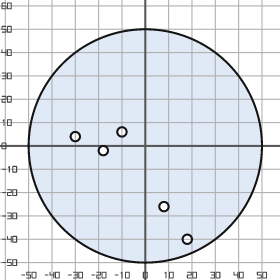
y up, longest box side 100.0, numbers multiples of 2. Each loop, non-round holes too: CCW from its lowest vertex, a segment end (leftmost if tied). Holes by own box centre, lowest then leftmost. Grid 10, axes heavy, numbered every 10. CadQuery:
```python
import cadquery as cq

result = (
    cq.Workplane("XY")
    .moveTo(0.0, 0.0)
    .circle(50.0)
    .moveTo(18.0, -40.0)
    .circle(2.0)
    .moveTo(8.0, -26.0)
    .circle(2.0)
    .moveTo(-18.0, -2.0)
    .circle(2.0)
    .moveTo(-30.0, 4.0)
    .circle(2.0)
    .moveTo(-10.0, 6.0)
    .circle(2.0)
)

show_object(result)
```